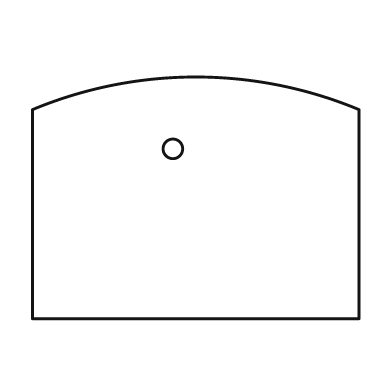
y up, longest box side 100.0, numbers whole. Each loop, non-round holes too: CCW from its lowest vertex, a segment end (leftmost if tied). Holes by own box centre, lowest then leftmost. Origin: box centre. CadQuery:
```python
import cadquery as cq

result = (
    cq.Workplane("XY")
    .moveTo(-50.0, -37.0)
    .lineTo(50.0, -37.0)
    .lineTo(50.0, 27.0)
    .threePointArc((0.0, 37.0), (-50.0, 27.0))
    .close()
    .moveTo(-7.0, 15.0)
    .circle(3.0)
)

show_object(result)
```